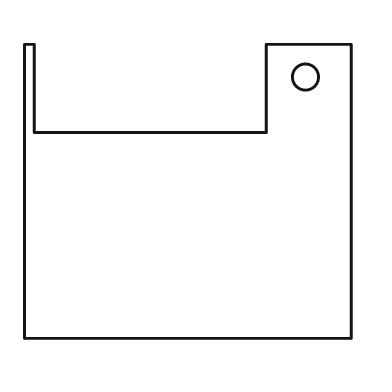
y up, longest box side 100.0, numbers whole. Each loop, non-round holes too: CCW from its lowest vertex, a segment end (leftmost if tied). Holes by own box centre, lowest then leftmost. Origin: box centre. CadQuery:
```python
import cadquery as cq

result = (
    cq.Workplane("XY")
    .moveTo(-50.0, -45.0)
    .lineTo(50.0, -45.0)
    .lineTo(50.0, 45.0)
    .lineTo(24.0, 45.0)
    .lineTo(24.0, 18.0)
    .lineTo(-47.0, 18.0)
    .lineTo(-47.0, 45.0)
    .lineTo(-50.0, 45.0)
    .close()
    .moveTo(36.0, 35.0)
    .circle(4.0)
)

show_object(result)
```